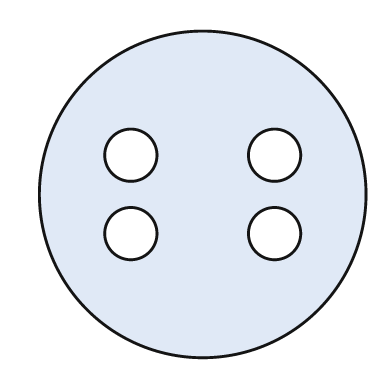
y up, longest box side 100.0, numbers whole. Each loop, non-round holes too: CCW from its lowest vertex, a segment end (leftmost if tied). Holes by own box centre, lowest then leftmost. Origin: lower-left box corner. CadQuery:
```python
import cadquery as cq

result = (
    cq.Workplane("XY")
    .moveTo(50.0, 50.0)
    .circle(50.0)
    .moveTo(28.0, 38.0)
    .circle(8.0)
    .moveTo(72.0, 38.0)
    .circle(8.0)
    .moveTo(28.0, 62.0)
    .circle(8.0)
    .moveTo(72.0, 62.0)
    .circle(8.0)
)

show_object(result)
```